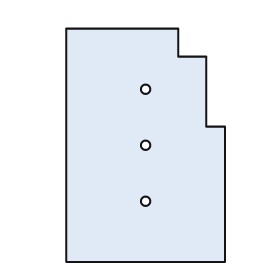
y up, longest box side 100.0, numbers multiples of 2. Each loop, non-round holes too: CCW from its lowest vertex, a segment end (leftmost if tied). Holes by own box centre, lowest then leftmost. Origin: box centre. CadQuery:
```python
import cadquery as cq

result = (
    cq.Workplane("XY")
    .moveTo(-34.0, -50.0)
    .lineTo(34.0, -50.0)
    .lineTo(34.0, 8.0)
    .lineTo(26.0, 8.0)
    .lineTo(26.0, 38.0)
    .lineTo(14.0, 38.0)
    .lineTo(14.0, 50.0)
    .lineTo(-34.0, 50.0)
    .close()
    .moveTo(0.0, -24.0)
    .circle(2.0)
    .moveTo(0.0, 0.0)
    .circle(2.0)
    .moveTo(0.0, 24.0)
    .circle(2.0)
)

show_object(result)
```